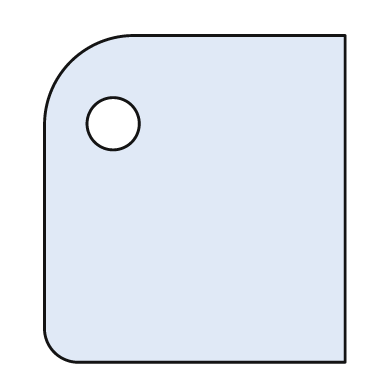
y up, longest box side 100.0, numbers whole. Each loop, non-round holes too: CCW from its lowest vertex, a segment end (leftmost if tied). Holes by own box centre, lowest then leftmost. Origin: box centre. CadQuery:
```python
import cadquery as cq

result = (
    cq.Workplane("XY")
    .moveTo(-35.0, -50.0)
    .lineTo(46.0, -50.0)
    .lineTo(46.0, 50.0)
    .lineTo(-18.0, 50.0)
    .threePointArc((-38.0, 42.0), (-46.0, 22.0))
    .lineTo(-46.0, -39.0)
    .threePointArc((-43.0, -47.0), (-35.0, -50.0))
    .close()
    .moveTo(-25.0, 23.0)
    .circle(8.0)
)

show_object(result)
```